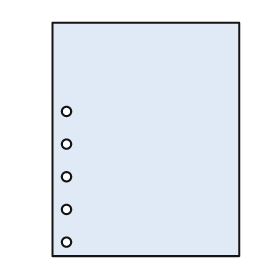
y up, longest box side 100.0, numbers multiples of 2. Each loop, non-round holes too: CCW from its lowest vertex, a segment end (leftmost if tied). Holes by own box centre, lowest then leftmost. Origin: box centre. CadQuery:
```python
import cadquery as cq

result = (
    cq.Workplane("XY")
    .moveTo(-40.0, -50.0)
    .lineTo(40.0, -50.0)
    .lineTo(40.0, 50.0)
    .lineTo(-40.0, 50.0)
    .close()
    .moveTo(-34.0, -44.0)
    .circle(2.0)
    .moveTo(-34.0, -30.0)
    .circle(2.0)
    .moveTo(-34.0, -16.0)
    .circle(2.0)
    .moveTo(-34.0, -2.0)
    .circle(2.0)
    .moveTo(-34.0, 12.0)
    .circle(2.0)
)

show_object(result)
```